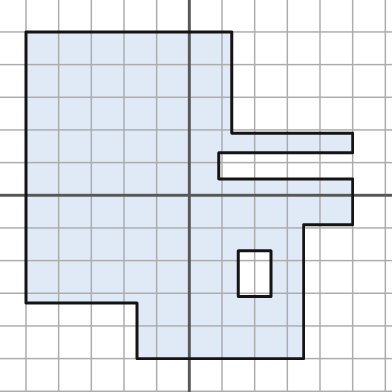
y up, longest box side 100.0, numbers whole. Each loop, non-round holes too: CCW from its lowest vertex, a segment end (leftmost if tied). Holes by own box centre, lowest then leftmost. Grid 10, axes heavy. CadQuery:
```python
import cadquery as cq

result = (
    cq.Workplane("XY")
    .moveTo(-16.0, -50.0)
    .lineTo(35.0, -50.0)
    .lineTo(35.0, -9.0)
    .lineTo(50.0, -9.0)
    .lineTo(50.0, 5.0)
    .lineTo(9.0, 5.0)
    .lineTo(9.0, 13.0)
    .lineTo(50.0, 13.0)
    .lineTo(50.0, 19.0)
    .lineTo(13.0, 19.0)
    .lineTo(13.0, 50.0)
    .lineTo(-50.0, 50.0)
    .lineTo(-50.0, -33.0)
    .lineTo(-16.0, -33.0)
    .close()
    .moveTo(15.0, -31.0)
    .lineTo(25.0, -31.0)
    .lineTo(25.0, -17.0)
    .lineTo(15.0, -17.0)
    .close()
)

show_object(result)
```